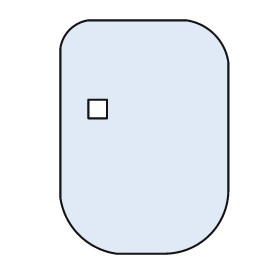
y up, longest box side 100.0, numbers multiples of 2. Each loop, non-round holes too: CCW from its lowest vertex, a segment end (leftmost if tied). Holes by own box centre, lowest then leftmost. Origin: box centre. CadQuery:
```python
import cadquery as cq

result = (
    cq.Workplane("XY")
    .moveTo(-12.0, -50.0)
    .lineTo(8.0, -50.0)
    .threePointArc((28.0, -42.0), (36.0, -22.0))
    .lineTo(36.0, 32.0)
    .threePointArc((30.0, 44.0), (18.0, 50.0))
    .lineTo(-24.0, 50.0)
    .threePointArc((-32.0, 46.0), (-36.0, 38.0))
    .lineTo(-36.0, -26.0)
    .threePointArc((-28.0, -42.0), (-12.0, -50.0))
    .close()
    .moveTo(-24.0, 8.0)
    .lineTo(-16.0, 8.0)
    .lineTo(-16.0, 16.0)
    .lineTo(-24.0, 16.0)
    .close()
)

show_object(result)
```